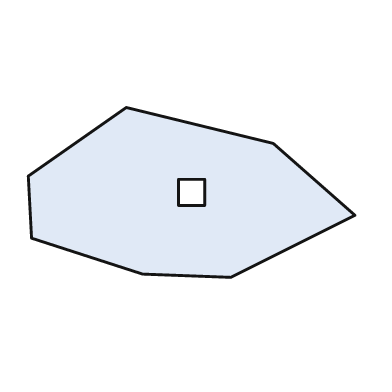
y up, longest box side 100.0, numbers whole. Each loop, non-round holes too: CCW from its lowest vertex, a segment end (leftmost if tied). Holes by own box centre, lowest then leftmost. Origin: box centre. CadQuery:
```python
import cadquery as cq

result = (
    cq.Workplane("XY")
    .moveTo(12.0, -26.0)
    .lineTo(50.0, -7.0)
    .lineTo(25.0, 15.0)
    .lineTo(-20.0, 26.0)
    .lineTo(-50.0, 5.0)
    .lineTo(-49.0, -14.0)
    .lineTo(-15.0, -25.0)
    .close()
    .moveTo(-4.0, -4.0)
    .lineTo(4.0, -4.0)
    .lineTo(4.0, 4.0)
    .lineTo(-4.0, 4.0)
    .close()
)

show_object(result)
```